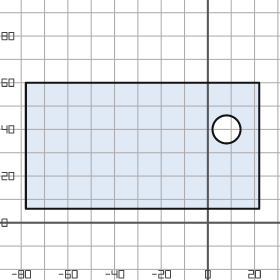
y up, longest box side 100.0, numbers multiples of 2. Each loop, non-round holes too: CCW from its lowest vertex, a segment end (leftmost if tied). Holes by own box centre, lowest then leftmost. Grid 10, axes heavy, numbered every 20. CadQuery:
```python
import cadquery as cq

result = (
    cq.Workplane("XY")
    .moveTo(-78.0, 6.0)
    .lineTo(22.0, 6.0)
    .lineTo(22.0, 60.0)
    .lineTo(-78.0, 60.0)
    .close()
    .moveTo(8.0, 40.0)
    .circle(6.0)
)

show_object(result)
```